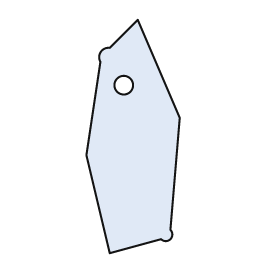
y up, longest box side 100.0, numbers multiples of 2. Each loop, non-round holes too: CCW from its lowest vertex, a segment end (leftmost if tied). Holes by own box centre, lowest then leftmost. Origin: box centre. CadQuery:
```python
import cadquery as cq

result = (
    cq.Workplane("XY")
    .moveTo(-10.0, -50.0)
    .lineTo(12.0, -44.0)
    .threePointArc((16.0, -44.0), (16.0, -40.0))
    .lineTo(20.0, 8.0)
    .lineTo(2.0, 50.0)
    .lineTo(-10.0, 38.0)
    .threePointArc((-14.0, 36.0), (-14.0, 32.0))
    .lineTo(-20.0, -8.0)
    .close()
    .moveTo(-4.0, 22.0)
    .circle(4.0)
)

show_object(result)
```